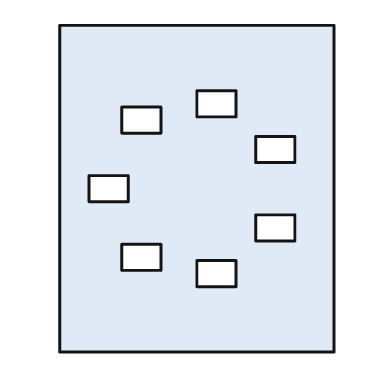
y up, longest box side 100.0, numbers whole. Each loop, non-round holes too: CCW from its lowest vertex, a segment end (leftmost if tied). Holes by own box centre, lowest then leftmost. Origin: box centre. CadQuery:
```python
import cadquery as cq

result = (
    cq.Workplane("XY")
    .moveTo(-42.0, -50.0)
    .lineTo(42.0, -50.0)
    .lineTo(42.0, 50.0)
    .lineTo(-42.0, 50.0)
    .close()
    .moveTo(0.0, -30.0)
    .lineTo(12.0, -30.0)
    .lineTo(12.0, -22.0)
    .lineTo(0.0, -22.0)
    .close()
    .moveTo(-23.0, -25.0)
    .lineTo(-11.0, -25.0)
    .lineTo(-11.0, -17.0)
    .lineTo(-23.0, -17.0)
    .close()
    .moveTo(18.0, -16.0)
    .lineTo(30.0, -16.0)
    .lineTo(30.0, -8.0)
    .lineTo(18.0, -8.0)
    .close()
    .moveTo(-33.0, -4.0)
    .lineTo(-21.0, -4.0)
    .lineTo(-21.0, 4.0)
    .lineTo(-33.0, 4.0)
    .close()
    .moveTo(18.0, 8.0)
    .lineTo(30.0, 8.0)
    .lineTo(30.0, 16.0)
    .lineTo(18.0, 16.0)
    .close()
    .moveTo(-23.0, 17.0)
    .lineTo(-11.0, 17.0)
    .lineTo(-11.0, 25.0)
    .lineTo(-23.0, 25.0)
    .close()
    .moveTo(0.0, 22.0)
    .lineTo(12.0, 22.0)
    .lineTo(12.0, 30.0)
    .lineTo(0.0, 30.0)
    .close()
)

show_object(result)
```